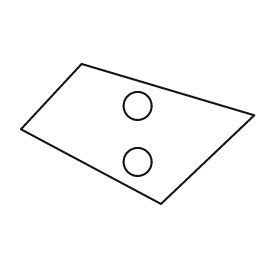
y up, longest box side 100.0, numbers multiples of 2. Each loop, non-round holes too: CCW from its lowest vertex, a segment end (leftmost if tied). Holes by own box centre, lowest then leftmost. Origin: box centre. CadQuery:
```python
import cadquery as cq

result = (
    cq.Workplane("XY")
    .moveTo(10.0, -30.0)
    .lineTo(50.0, 8.0)
    .lineTo(-24.0, 30.0)
    .lineTo(-50.0, 2.0)
    .close()
    .moveTo(0.0, -12.0)
    .circle(6.0)
    .moveTo(0.0, 12.0)
    .circle(6.0)
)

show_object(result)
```